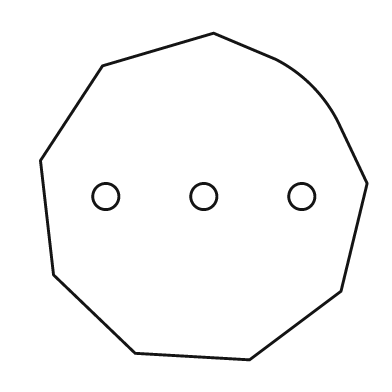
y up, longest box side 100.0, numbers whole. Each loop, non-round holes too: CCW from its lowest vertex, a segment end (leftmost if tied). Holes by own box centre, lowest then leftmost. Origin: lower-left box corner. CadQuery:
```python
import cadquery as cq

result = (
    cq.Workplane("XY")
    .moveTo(64.0, 0.0)
    .lineTo(92.0, 21.0)
    .lineTo(100.0, 54.0)
    .lineTo(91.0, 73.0)
    .threePointArc((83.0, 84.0), (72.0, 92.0))
    .lineTo(53.0, 100.0)
    .lineTo(19.0, 90.0)
    .lineTo(0.0, 61.0)
    .lineTo(4.0, 26.0)
    .lineTo(29.0, 2.0)
    .close()
    .moveTo(20.0, 50.0)
    .circle(4.0)
    .moveTo(50.0, 50.0)
    .circle(4.0)
    .moveTo(80.0, 50.0)
    .circle(4.0)
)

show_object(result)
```